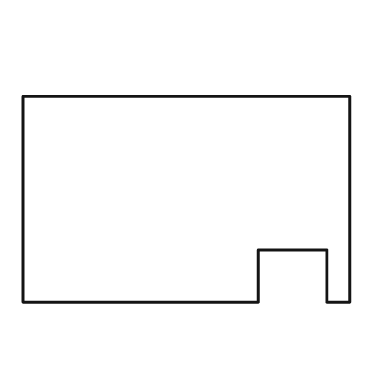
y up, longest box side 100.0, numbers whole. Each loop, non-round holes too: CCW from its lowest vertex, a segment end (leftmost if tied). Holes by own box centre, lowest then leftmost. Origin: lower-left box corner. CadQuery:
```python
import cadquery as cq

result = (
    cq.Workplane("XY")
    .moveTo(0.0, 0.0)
    .lineTo(72.0, 0.0)
    .lineTo(72.0, 16.0)
    .lineTo(93.0, 16.0)
    .lineTo(93.0, 0.0)
    .lineTo(100.0, 0.0)
    .lineTo(100.0, 63.0)
    .lineTo(0.0, 63.0)
    .close()
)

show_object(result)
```